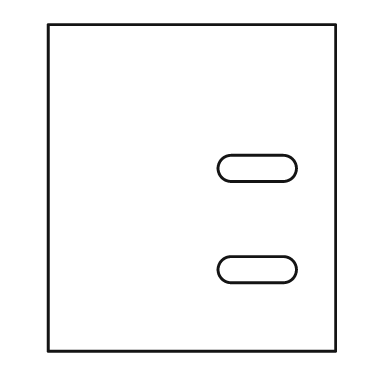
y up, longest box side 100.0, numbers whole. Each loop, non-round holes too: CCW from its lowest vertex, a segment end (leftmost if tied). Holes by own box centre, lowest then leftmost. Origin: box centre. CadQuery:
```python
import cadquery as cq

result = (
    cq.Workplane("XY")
    .moveTo(-44.0, -50.0)
    .lineTo(44.0, -50.0)
    .lineTo(44.0, 50.0)
    .lineTo(-44.0, 50.0)
    .close()
    .moveTo(12.0, -29.0)
    .lineTo(28.0, -29.0)
    .threePointArc((32.0, -25.0), (28.0, -21.0))
    .lineTo(12.0, -21.0)
    .threePointArc((8.0, -25.0), (12.0, -29.0))
    .close()
    .moveTo(12.0, 2.0)
    .lineTo(28.0, 2.0)
    .threePointArc((32.0, 6.0), (28.0, 10.0))
    .lineTo(12.0, 10.0)
    .threePointArc((8.0, 6.0), (12.0, 2.0))
    .close()
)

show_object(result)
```